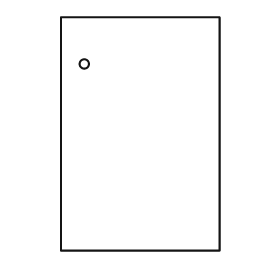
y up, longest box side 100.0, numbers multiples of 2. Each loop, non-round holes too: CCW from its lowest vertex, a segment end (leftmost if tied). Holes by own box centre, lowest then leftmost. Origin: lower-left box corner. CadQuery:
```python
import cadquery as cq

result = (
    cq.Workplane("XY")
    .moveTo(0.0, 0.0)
    .lineTo(68.0, 0.0)
    .lineTo(68.0, 100.0)
    .lineTo(0.0, 100.0)
    .close()
    .moveTo(10.0, 80.0)
    .circle(2.0)
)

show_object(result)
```